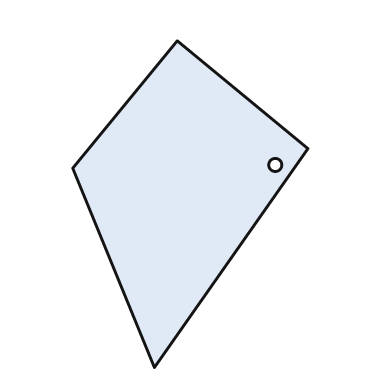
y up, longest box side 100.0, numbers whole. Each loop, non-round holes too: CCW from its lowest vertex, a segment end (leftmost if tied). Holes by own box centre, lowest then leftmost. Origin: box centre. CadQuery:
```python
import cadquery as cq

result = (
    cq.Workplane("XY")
    .moveTo(-11.0, -50.0)
    .lineTo(36.0, 17.0)
    .lineTo(-4.0, 50.0)
    .lineTo(-36.0, 11.0)
    .close()
    .moveTo(26.0, 12.0)
    .circle(2.0)
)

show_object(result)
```